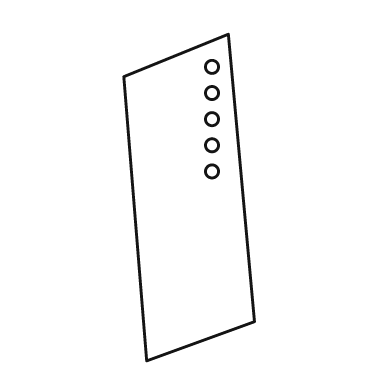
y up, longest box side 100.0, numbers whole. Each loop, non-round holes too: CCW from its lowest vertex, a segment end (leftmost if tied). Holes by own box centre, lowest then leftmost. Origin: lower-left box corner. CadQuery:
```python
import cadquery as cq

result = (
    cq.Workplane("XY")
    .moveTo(7.0, 0.0)
    .lineTo(40.0, 12.0)
    .lineTo(32.0, 100.0)
    .lineTo(0.0, 87.0)
    .close()
    .moveTo(27.0, 58.0)
    .circle(2.0)
    .moveTo(27.0, 66.0)
    .circle(2.0)
    .moveTo(27.0, 74.0)
    .circle(2.0)
    .moveTo(27.0, 82.0)
    .circle(2.0)
    .moveTo(27.0, 90.0)
    .circle(2.0)
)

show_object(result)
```